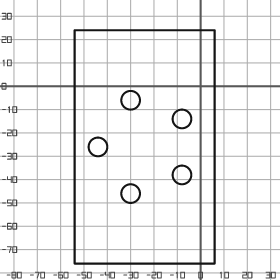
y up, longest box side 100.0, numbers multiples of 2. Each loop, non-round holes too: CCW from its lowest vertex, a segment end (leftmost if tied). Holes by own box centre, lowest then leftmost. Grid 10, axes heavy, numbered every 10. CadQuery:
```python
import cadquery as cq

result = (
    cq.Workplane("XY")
    .moveTo(-54.0, -76.0)
    .lineTo(6.0, -76.0)
    .lineTo(6.0, 24.0)
    .lineTo(-54.0, 24.0)
    .close()
    .moveTo(-30.0, -46.0)
    .circle(4.0)
    .moveTo(-8.0, -38.0)
    .circle(4.0)
    .moveTo(-44.0, -26.0)
    .circle(4.0)
    .moveTo(-8.0, -14.0)
    .circle(4.0)
    .moveTo(-30.0, -6.0)
    .circle(4.0)
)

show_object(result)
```